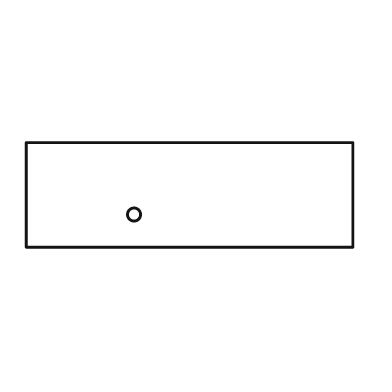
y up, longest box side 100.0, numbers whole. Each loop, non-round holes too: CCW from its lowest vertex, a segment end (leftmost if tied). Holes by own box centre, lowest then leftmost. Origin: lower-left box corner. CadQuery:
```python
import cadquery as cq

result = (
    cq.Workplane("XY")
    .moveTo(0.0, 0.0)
    .lineTo(100.0, 0.0)
    .lineTo(100.0, 32.0)
    .lineTo(0.0, 32.0)
    .close()
    .moveTo(33.0, 10.0)
    .circle(2.0)
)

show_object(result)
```